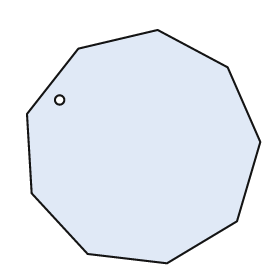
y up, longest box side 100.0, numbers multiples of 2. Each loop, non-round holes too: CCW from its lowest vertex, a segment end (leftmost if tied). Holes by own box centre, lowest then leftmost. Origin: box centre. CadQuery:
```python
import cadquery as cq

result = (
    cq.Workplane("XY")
    .moveTo(10.0, -50.0)
    .lineTo(40.0, -32.0)
    .lineTo(50.0, 2.0)
    .lineTo(36.0, 34.0)
    .lineTo(6.0, 50.0)
    .lineTo(-28.0, 42.0)
    .lineTo(-50.0, 14.0)
    .lineTo(-48.0, -20.0)
    .lineTo(-24.0, -46.0)
    .close()
    .moveTo(-36.0, 20.0)
    .circle(2.0)
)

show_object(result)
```